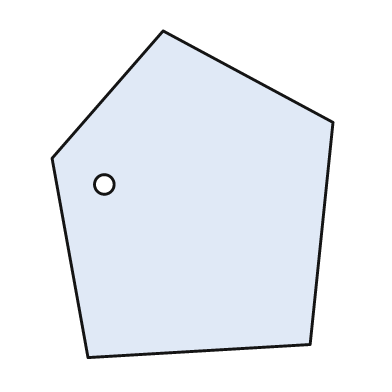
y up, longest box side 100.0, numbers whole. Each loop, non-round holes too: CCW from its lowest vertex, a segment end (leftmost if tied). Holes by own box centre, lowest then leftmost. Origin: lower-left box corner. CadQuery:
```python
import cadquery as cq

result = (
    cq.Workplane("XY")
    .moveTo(11.0, 0.0)
    .lineTo(79.0, 4.0)
    .lineTo(86.0, 72.0)
    .lineTo(34.0, 100.0)
    .lineTo(0.0, 61.0)
    .close()
    .moveTo(16.0, 53.0)
    .circle(3.0)
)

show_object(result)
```